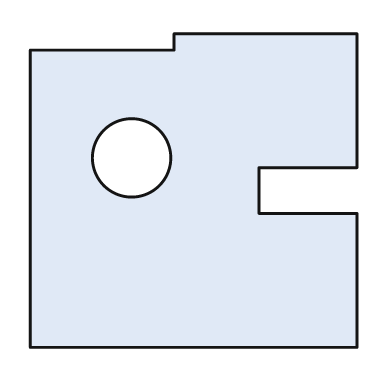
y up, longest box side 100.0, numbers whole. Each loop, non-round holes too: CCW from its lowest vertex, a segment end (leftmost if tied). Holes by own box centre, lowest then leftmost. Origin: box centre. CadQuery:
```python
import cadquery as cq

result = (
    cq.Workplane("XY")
    .moveTo(-50.0, -48.0)
    .lineTo(50.0, -48.0)
    .lineTo(50.0, -7.0)
    .lineTo(20.0, -7.0)
    .lineTo(20.0, 7.0)
    .lineTo(50.0, 7.0)
    .lineTo(50.0, 48.0)
    .lineTo(-6.0, 48.0)
    .lineTo(-6.0, 43.0)
    .lineTo(-50.0, 43.0)
    .close()
    .moveTo(-19.0, 10.0)
    .circle(12.0)
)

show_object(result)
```